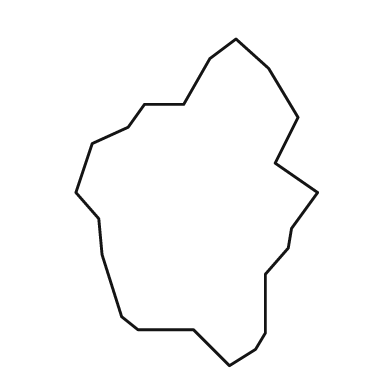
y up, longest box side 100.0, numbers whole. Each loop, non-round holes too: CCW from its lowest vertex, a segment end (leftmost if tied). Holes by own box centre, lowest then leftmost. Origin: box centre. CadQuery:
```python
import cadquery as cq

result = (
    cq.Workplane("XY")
    .moveTo(10.0, -50.0)
    .lineTo(18.0, -45.0)
    .lineTo(21.0, -40.0)
    .lineTo(21.0, -22.0)
    .lineTo(28.0, -14.0)
    .lineTo(29.0, -8.0)
    .lineTo(37.0, 3.0)
    .lineTo(24.0, 12.0)
    .lineTo(31.0, 26.0)
    .lineTo(22.0, 41.0)
    .lineTo(12.0, 50.0)
    .lineTo(4.0, 44.0)
    .lineTo(-4.0, 30.0)
    .lineTo(-16.0, 30.0)
    .lineTo(-21.0, 23.0)
    .lineTo(-32.0, 18.0)
    .lineTo(-37.0, 3.0)
    .lineTo(-30.0, -5.0)
    .lineTo(-29.0, -16.0)
    .lineTo(-23.0, -35.0)
    .lineTo(-18.0, -39.0)
    .lineTo(-1.0, -39.0)
    .close()
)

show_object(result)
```